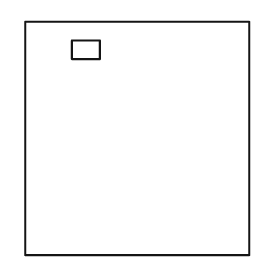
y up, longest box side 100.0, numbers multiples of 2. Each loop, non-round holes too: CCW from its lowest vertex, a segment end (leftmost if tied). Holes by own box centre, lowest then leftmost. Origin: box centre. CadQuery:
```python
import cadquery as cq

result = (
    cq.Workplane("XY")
    .moveTo(-48.0, -50.0)
    .lineTo(48.0, -50.0)
    .lineTo(48.0, 50.0)
    .lineTo(-48.0, 50.0)
    .close()
    .moveTo(-28.0, 34.0)
    .lineTo(-16.0, 34.0)
    .lineTo(-16.0, 42.0)
    .lineTo(-28.0, 42.0)
    .close()
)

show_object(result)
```